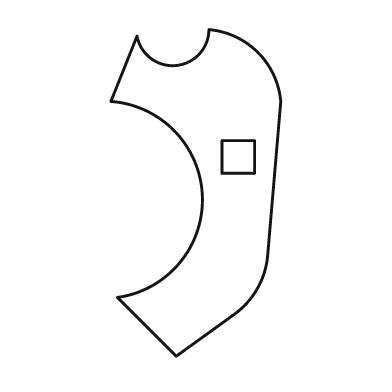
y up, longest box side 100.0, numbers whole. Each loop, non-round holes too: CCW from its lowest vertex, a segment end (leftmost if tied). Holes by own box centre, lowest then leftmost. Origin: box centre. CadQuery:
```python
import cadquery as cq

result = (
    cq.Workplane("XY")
    .moveTo(-6.0, -50.0)
    .lineTo(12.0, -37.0)
    .threePointArc((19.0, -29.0), (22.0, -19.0))
    .lineTo(26.0, 28.0)
    .threePointArc((19.0, 43.0), (4.0, 50.0))
    .threePointArc((-6.0, 39.0), (-18.0, 48.0))
    .lineTo(-26.0, 28.0)
    .threePointArc((2.0, -1.0), (-24.0, -32.0))
    .close()
    .moveTo(8.0, 6.0)
    .lineTo(18.0, 6.0)
    .lineTo(18.0, 16.0)
    .lineTo(8.0, 16.0)
    .close()
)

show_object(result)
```